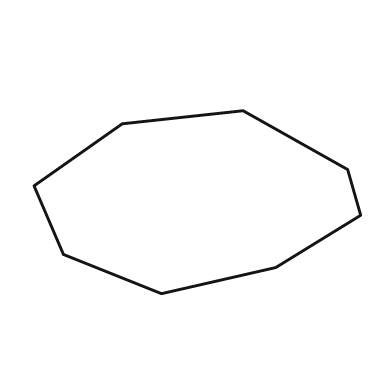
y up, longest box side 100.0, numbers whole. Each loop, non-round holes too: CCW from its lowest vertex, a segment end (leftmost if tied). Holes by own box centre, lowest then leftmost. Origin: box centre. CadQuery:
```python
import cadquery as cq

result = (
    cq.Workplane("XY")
    .moveTo(-11.0, -28.0)
    .lineTo(24.0, -20.0)
    .lineTo(50.0, -4.0)
    .lineTo(46.0, 10.0)
    .lineTo(14.0, 28.0)
    .lineTo(-23.0, 24.0)
    .lineTo(-50.0, 5.0)
    .lineTo(-41.0, -16.0)
    .close()
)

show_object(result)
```